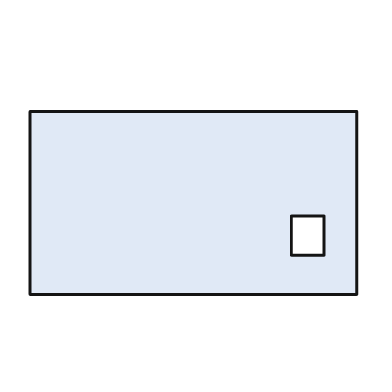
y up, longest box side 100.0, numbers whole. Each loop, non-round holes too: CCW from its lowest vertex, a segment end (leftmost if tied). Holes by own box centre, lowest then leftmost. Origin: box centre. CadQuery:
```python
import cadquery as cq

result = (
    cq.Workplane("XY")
    .moveTo(-50.0, -28.0)
    .lineTo(50.0, -28.0)
    .lineTo(50.0, 28.0)
    .lineTo(-50.0, 28.0)
    .close()
    .moveTo(30.0, -16.0)
    .lineTo(40.0, -16.0)
    .lineTo(40.0, -4.0)
    .lineTo(30.0, -4.0)
    .close()
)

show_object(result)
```